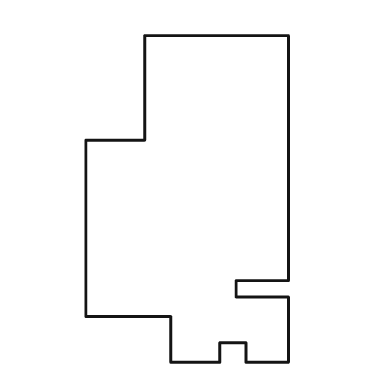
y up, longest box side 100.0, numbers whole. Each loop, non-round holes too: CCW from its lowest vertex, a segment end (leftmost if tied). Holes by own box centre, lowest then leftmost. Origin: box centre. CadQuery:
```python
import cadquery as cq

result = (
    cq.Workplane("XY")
    .moveTo(-5.0, -50.0)
    .lineTo(10.0, -50.0)
    .lineTo(10.0, -44.0)
    .lineTo(18.0, -44.0)
    .lineTo(18.0, -50.0)
    .lineTo(31.0, -50.0)
    .lineTo(31.0, -30.0)
    .lineTo(15.0, -30.0)
    .lineTo(15.0, -25.0)
    .lineTo(31.0, -25.0)
    .lineTo(31.0, 50.0)
    .lineTo(-13.0, 50.0)
    .lineTo(-13.0, 18.0)
    .lineTo(-31.0, 18.0)
    .lineTo(-31.0, -36.0)
    .lineTo(-5.0, -36.0)
    .close()
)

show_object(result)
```